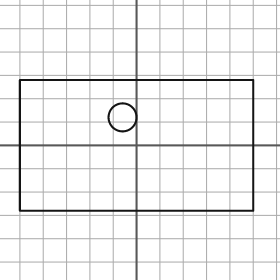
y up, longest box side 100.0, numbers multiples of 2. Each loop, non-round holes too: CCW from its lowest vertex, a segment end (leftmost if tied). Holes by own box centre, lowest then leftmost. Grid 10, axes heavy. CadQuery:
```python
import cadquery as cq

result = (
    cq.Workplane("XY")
    .moveTo(-50.0, -28.0)
    .lineTo(50.0, -28.0)
    .lineTo(50.0, 28.0)
    .lineTo(-50.0, 28.0)
    .close()
    .moveTo(-6.0, 12.0)
    .circle(6.0)
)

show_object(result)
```